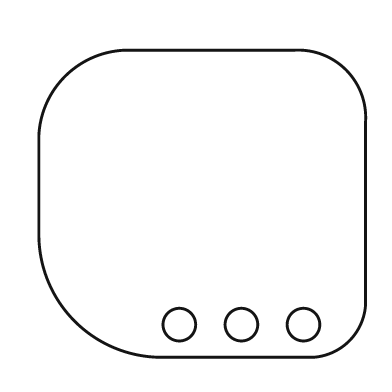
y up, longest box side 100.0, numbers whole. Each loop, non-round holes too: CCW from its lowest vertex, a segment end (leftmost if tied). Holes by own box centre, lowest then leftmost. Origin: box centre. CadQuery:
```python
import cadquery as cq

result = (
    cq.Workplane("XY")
    .moveTo(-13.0, -47.0)
    .lineTo(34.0, -47.0)
    .threePointArc((45.0, -42.0), (50.0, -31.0))
    .lineTo(50.0, 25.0)
    .threePointArc((44.0, 41.0), (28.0, 47.0))
    .lineTo(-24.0, 47.0)
    .threePointArc((-42.0, 39.0), (-50.0, 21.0))
    .lineTo(-50.0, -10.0)
    .threePointArc((-39.0, -36.0), (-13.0, -47.0))
    .close()
    .moveTo(-7.0, -37.0)
    .circle(5.0)
    .moveTo(12.0, -37.0)
    .circle(5.0)
    .moveTo(31.0, -37.0)
    .circle(5.0)
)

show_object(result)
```